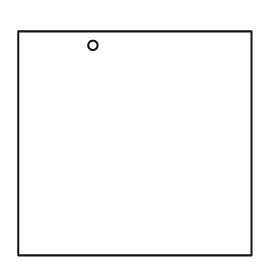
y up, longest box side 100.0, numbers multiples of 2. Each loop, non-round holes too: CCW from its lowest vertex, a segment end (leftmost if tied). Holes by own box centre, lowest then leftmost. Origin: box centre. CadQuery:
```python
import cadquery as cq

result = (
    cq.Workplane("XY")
    .moveTo(-50.0, -48.0)
    .lineTo(50.0, -48.0)
    .lineTo(50.0, 48.0)
    .lineTo(-50.0, 48.0)
    .close()
    .moveTo(-18.0, 42.0)
    .circle(2.0)
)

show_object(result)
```